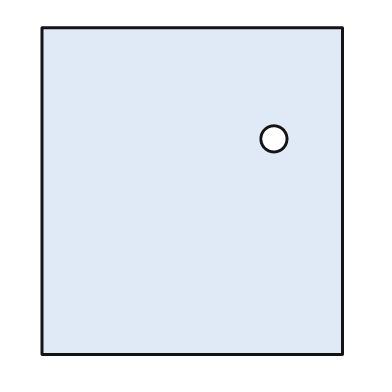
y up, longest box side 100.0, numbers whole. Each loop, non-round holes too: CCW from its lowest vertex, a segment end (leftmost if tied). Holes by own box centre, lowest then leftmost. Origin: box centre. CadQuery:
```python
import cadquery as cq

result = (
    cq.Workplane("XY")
    .moveTo(-46.0, -50.0)
    .lineTo(46.0, -50.0)
    .lineTo(46.0, 50.0)
    .lineTo(-46.0, 50.0)
    .close()
    .moveTo(25.0, 16.0)
    .circle(4.0)
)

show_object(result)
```